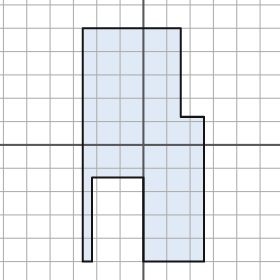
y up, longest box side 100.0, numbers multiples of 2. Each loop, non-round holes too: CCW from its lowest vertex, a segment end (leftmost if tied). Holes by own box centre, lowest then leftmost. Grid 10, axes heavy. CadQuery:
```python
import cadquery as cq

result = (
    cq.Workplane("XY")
    .moveTo(-26.0, -50.0)
    .lineTo(-22.0, -50.0)
    .lineTo(-22.0, -14.0)
    .lineTo(0.0, -14.0)
    .lineTo(0.0, -50.0)
    .lineTo(26.0, -50.0)
    .lineTo(26.0, 12.0)
    .lineTo(16.0, 12.0)
    .lineTo(16.0, 50.0)
    .lineTo(-26.0, 50.0)
    .close()
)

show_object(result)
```